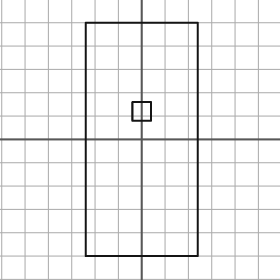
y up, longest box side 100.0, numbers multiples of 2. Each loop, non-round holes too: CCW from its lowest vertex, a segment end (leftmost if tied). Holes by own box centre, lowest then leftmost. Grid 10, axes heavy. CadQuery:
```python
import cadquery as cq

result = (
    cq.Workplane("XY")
    .moveTo(-24.0, -50.0)
    .lineTo(24.0, -50.0)
    .lineTo(24.0, 50.0)
    .lineTo(-24.0, 50.0)
    .close()
    .moveTo(-4.0, 8.0)
    .lineTo(4.0, 8.0)
    .lineTo(4.0, 16.0)
    .lineTo(-4.0, 16.0)
    .close()
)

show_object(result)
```